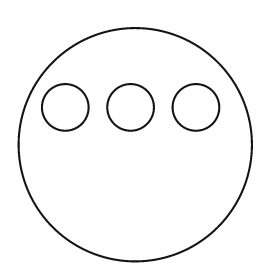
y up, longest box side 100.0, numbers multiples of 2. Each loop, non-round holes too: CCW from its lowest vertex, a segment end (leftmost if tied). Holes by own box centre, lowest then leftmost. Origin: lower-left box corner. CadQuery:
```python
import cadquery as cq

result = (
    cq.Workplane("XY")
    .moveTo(50.0, 50.0)
    .circle(50.0)
    .moveTo(20.0, 66.0)
    .circle(10.0)
    .moveTo(48.0, 66.0)
    .circle(10.0)
    .moveTo(76.0, 66.0)
    .circle(10.0)
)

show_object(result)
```